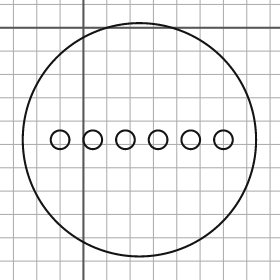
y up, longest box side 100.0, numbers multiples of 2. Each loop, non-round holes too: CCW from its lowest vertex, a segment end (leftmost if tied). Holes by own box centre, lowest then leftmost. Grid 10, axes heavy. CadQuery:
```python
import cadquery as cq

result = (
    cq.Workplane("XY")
    .moveTo(24.0, -48.0)
    .circle(50.0)
    .moveTo(-10.0, -48.0)
    .circle(4.0)
    .moveTo(4.0, -48.0)
    .circle(4.0)
    .moveTo(18.0, -48.0)
    .circle(4.0)
    .moveTo(32.0, -48.0)
    .circle(4.0)
    .moveTo(46.0, -48.0)
    .circle(4.0)
    .moveTo(60.0, -48.0)
    .circle(4.0)
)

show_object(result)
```